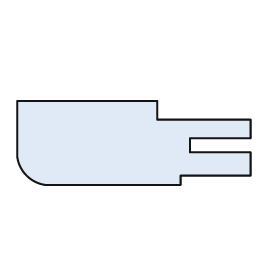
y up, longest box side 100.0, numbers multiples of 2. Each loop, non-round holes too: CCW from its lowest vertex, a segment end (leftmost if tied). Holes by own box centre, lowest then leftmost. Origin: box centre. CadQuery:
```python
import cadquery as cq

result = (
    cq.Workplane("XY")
    .moveTo(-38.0, -18.0)
    .lineTo(20.0, -18.0)
    .lineTo(20.0, -14.0)
    .lineTo(50.0, -14.0)
    .lineTo(50.0, -4.0)
    .lineTo(24.0, -4.0)
    .lineTo(24.0, 2.0)
    .lineTo(50.0, 2.0)
    .lineTo(50.0, 10.0)
    .lineTo(10.0, 10.0)
    .lineTo(10.0, 18.0)
    .lineTo(-50.0, 18.0)
    .lineTo(-50.0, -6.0)
    .threePointArc((-46.0, -14.0), (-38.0, -18.0))
    .close()
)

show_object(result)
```